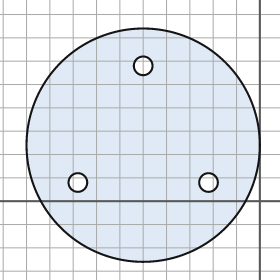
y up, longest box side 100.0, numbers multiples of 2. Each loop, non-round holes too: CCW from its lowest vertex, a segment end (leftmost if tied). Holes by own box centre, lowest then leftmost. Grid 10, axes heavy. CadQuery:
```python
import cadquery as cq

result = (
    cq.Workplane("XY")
    .moveTo(-50.0, 24.0)
    .circle(50.0)
    .moveTo(-78.0, 8.0)
    .circle(4.0)
    .moveTo(-22.0, 8.0)
    .circle(4.0)
    .moveTo(-50.0, 58.0)
    .circle(4.0)
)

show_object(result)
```